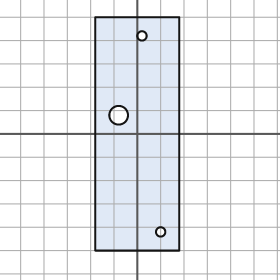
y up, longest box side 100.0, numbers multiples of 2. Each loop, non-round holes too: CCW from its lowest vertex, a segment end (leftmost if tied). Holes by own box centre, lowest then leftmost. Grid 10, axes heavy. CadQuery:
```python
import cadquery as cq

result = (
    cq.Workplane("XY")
    .moveTo(-18.0, -50.0)
    .lineTo(18.0, -50.0)
    .lineTo(18.0, 50.0)
    .lineTo(-18.0, 50.0)
    .close()
    .moveTo(10.0, -42.0)
    .circle(2.0)
    .moveTo(-8.0, 8.0)
    .circle(4.0)
    .moveTo(2.0, 42.0)
    .circle(2.0)
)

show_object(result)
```